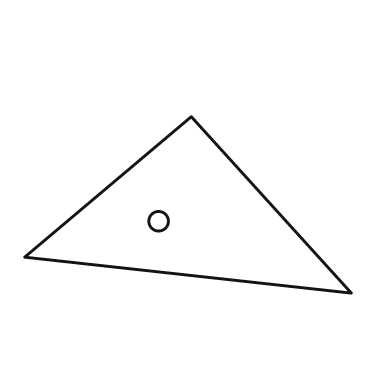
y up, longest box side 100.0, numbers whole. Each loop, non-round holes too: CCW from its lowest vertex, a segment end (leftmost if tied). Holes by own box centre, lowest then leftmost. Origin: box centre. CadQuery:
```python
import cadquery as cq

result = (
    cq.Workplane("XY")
    .moveTo(50.0, -27.0)
    .lineTo(1.0, 27.0)
    .lineTo(-50.0, -16.0)
    .close()
    .moveTo(-9.0, -5.0)
    .circle(3.0)
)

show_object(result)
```